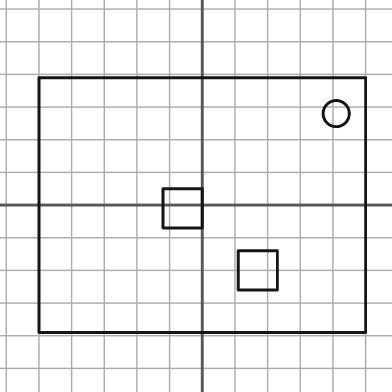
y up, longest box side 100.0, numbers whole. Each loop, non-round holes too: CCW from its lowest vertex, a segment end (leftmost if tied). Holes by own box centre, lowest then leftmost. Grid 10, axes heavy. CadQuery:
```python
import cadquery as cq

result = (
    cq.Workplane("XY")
    .moveTo(-50.0, -39.0)
    .lineTo(50.0, -39.0)
    .lineTo(50.0, 39.0)
    .lineTo(-50.0, 39.0)
    .close()
    .moveTo(11.0, -26.0)
    .lineTo(23.0, -26.0)
    .lineTo(23.0, -14.0)
    .lineTo(11.0, -14.0)
    .close()
    .moveTo(-12.0, -7.0)
    .lineTo(0.0, -7.0)
    .lineTo(0.0, 5.0)
    .lineTo(-12.0, 5.0)
    .close()
    .moveTo(41.0, 28.0)
    .circle(4.0)
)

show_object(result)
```